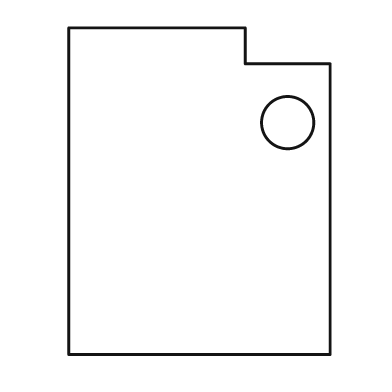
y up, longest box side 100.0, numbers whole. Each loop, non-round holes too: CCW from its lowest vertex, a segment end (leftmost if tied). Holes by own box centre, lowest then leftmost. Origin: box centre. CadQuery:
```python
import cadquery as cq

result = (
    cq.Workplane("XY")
    .moveTo(-40.0, -50.0)
    .lineTo(40.0, -50.0)
    .lineTo(40.0, 39.0)
    .lineTo(14.0, 39.0)
    .lineTo(14.0, 50.0)
    .lineTo(-40.0, 50.0)
    .close()
    .moveTo(27.0, 21.0)
    .circle(8.0)
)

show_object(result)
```